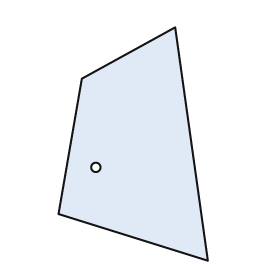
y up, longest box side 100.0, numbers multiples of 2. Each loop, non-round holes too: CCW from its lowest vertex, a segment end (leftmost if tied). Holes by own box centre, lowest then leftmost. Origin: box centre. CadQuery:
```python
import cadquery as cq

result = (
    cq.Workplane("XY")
    .moveTo(32.0, -50.0)
    .lineTo(18.0, 50.0)
    .lineTo(-22.0, 28.0)
    .lineTo(-32.0, -30.0)
    .close()
    .moveTo(-16.0, -10.0)
    .circle(2.0)
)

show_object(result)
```